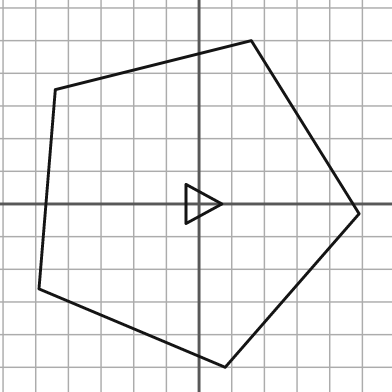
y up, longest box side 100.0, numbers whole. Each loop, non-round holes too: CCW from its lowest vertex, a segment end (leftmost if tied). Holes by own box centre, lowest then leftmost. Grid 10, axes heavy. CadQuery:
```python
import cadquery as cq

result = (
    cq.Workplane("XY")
    .moveTo(8.0, -50.0)
    .lineTo(49.0, -3.0)
    .lineTo(16.0, 50.0)
    .lineTo(-44.0, 35.0)
    .lineTo(-49.0, -26.0)
    .close()
    .moveTo(-4.0, -6.0)
    .lineTo(7.0, 0.0)
    .lineTo(-4.0, 6.0)
    .close()
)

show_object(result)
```